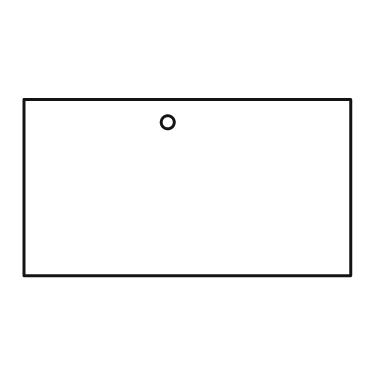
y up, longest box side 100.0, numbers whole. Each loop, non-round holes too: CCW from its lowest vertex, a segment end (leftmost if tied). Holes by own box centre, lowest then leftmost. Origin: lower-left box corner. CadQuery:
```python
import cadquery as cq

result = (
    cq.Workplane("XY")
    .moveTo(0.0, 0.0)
    .lineTo(100.0, 0.0)
    .lineTo(100.0, 54.0)
    .lineTo(0.0, 54.0)
    .close()
    .moveTo(44.0, 47.0)
    .circle(2.0)
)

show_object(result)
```